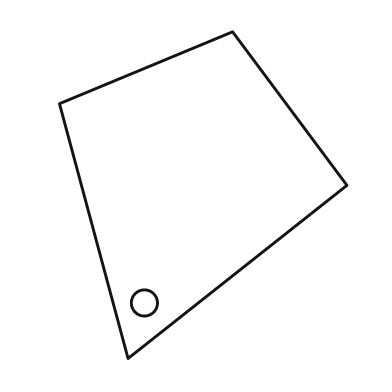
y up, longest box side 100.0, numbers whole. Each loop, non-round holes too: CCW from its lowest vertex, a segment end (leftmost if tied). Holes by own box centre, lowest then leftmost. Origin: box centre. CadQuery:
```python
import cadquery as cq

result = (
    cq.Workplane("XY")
    .moveTo(-23.0, -50.0)
    .lineTo(44.0, 3.0)
    .lineTo(9.0, 50.0)
    .lineTo(-44.0, 28.0)
    .close()
    .moveTo(-18.0, -33.0)
    .circle(4.0)
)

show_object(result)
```